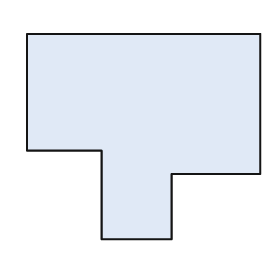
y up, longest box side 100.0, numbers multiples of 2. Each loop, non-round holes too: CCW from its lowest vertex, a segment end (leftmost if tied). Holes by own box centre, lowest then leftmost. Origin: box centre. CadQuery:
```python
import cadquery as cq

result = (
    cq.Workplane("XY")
    .moveTo(-18.0, -44.0)
    .lineTo(12.0, -44.0)
    .lineTo(12.0, -16.0)
    .lineTo(50.0, -16.0)
    .lineTo(50.0, 44.0)
    .lineTo(-50.0, 44.0)
    .lineTo(-50.0, -6.0)
    .lineTo(-18.0, -6.0)
    .close()
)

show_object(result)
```